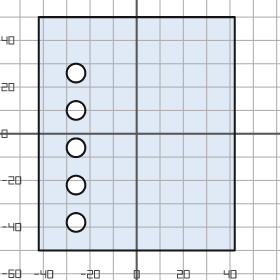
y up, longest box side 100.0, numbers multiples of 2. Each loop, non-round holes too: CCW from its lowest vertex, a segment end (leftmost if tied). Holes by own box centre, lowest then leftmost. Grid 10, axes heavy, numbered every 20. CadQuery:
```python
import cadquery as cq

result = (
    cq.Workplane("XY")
    .moveTo(-42.0, -50.0)
    .lineTo(42.0, -50.0)
    .lineTo(42.0, 50.0)
    .lineTo(-42.0, 50.0)
    .close()
    .moveTo(-26.0, -38.0)
    .circle(4.0)
    .moveTo(-26.0, -22.0)
    .circle(4.0)
    .moveTo(-26.0, -6.0)
    .circle(4.0)
    .moveTo(-26.0, 10.0)
    .circle(4.0)
    .moveTo(-26.0, 26.0)
    .circle(4.0)
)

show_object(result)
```